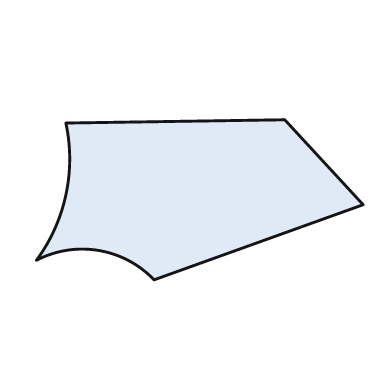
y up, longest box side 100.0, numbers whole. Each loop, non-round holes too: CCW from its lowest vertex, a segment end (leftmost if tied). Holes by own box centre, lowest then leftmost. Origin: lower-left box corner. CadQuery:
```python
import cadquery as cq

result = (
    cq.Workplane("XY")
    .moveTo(36.0, 0.0)
    .lineTo(100.0, 23.0)
    .lineTo(76.0, 49.0)
    .lineTo(9.0, 48.0)
    .threePointArc((9.0, 26.0), (0.0, 6.0))
    .threePointArc((19.0, 9.0), (36.0, 0.0))
    .close()
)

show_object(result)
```